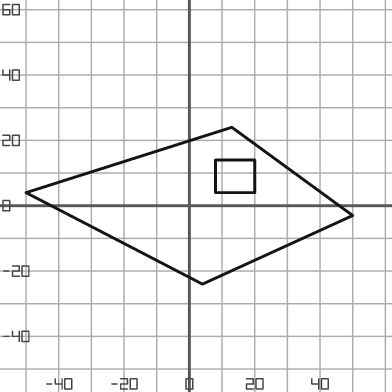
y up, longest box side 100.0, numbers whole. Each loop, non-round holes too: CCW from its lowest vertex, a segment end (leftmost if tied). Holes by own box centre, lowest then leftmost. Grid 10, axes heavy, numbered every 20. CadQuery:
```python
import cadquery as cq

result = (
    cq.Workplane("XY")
    .moveTo(4.0, -24.0)
    .lineTo(50.0, -3.0)
    .lineTo(13.0, 24.0)
    .lineTo(-50.0, 4.0)
    .close()
    .moveTo(8.0, 4.0)
    .lineTo(20.0, 4.0)
    .lineTo(20.0, 14.0)
    .lineTo(8.0, 14.0)
    .close()
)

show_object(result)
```